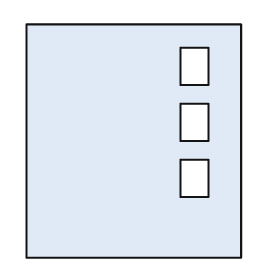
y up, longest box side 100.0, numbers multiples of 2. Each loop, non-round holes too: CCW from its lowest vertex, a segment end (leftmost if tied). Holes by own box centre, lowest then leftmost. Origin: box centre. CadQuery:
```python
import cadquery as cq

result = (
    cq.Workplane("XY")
    .moveTo(-46.0, -50.0)
    .lineTo(46.0, -50.0)
    .lineTo(46.0, 50.0)
    .lineTo(-46.0, 50.0)
    .close()
    .moveTo(20.0, -24.0)
    .lineTo(32.0, -24.0)
    .lineTo(32.0, -8.0)
    .lineTo(20.0, -8.0)
    .close()
    .moveTo(20.0, 0.0)
    .lineTo(32.0, 0.0)
    .lineTo(32.0, 16.0)
    .lineTo(20.0, 16.0)
    .close()
    .moveTo(20.0, 24.0)
    .lineTo(32.0, 24.0)
    .lineTo(32.0, 40.0)
    .lineTo(20.0, 40.0)
    .close()
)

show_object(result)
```